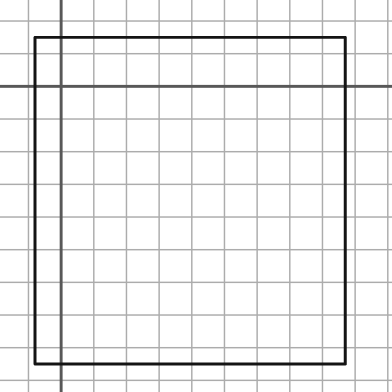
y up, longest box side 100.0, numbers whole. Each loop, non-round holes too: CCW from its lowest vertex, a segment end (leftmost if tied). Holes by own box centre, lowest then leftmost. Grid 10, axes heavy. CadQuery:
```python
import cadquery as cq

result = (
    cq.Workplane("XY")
    .moveTo(-8.0, -85.0)
    .lineTo(87.0, -85.0)
    .lineTo(87.0, 15.0)
    .lineTo(-8.0, 15.0)
    .close()
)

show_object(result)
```